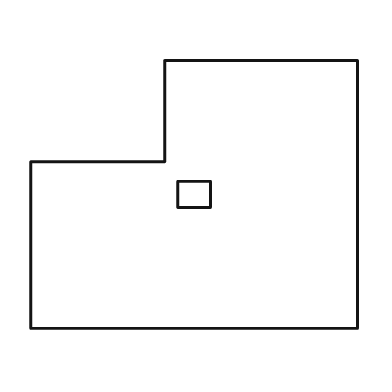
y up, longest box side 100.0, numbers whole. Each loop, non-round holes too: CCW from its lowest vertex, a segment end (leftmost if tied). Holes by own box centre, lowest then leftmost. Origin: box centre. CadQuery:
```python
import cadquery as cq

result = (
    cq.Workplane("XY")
    .moveTo(-50.0, -41.0)
    .lineTo(50.0, -41.0)
    .lineTo(50.0, 41.0)
    .lineTo(-9.0, 41.0)
    .lineTo(-9.0, 10.0)
    .lineTo(-50.0, 10.0)
    .close()
    .moveTo(-5.0, -4.0)
    .lineTo(5.0, -4.0)
    .lineTo(5.0, 4.0)
    .lineTo(-5.0, 4.0)
    .close()
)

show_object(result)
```